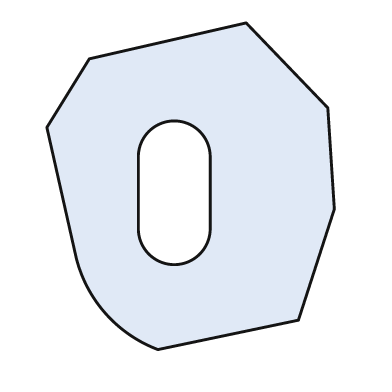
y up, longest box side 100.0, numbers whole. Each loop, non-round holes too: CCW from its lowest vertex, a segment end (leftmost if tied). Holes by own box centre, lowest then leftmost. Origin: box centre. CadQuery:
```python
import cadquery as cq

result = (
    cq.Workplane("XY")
    .moveTo(-10.0, -50.0)
    .lineTo(33.0, -41.0)
    .lineTo(44.0, -7.0)
    .lineTo(42.0, 24.0)
    .lineTo(17.0, 50.0)
    .lineTo(-31.0, 39.0)
    .lineTo(-44.0, 18.0)
    .lineTo(-35.0, -22.0)
    .threePointArc((-26.0, -39.0), (-10.0, -50.0))
    .close()
    .moveTo(-16.0, -13.0)
    .threePointArc((-5.0, -24.0), (6.0, -13.0))
    .lineTo(6.0, 9.0)
    .threePointArc((-5.0, 20.0), (-16.0, 9.0))
    .close()
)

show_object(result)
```